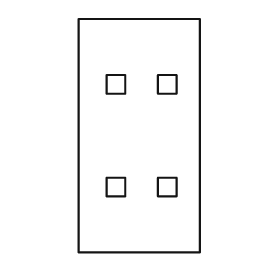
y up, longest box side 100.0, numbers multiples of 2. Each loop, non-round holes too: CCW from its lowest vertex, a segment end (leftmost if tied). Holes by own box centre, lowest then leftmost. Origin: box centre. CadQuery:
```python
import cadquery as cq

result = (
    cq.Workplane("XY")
    .moveTo(-26.0, -50.0)
    .lineTo(26.0, -50.0)
    .lineTo(26.0, 50.0)
    .lineTo(-26.0, 50.0)
    .close()
    .moveTo(-14.0, -26.0)
    .lineTo(-6.0, -26.0)
    .lineTo(-6.0, -18.0)
    .lineTo(-14.0, -18.0)
    .close()
    .moveTo(8.0, -26.0)
    .lineTo(16.0, -26.0)
    .lineTo(16.0, -18.0)
    .lineTo(8.0, -18.0)
    .close()
    .moveTo(-14.0, 18.0)
    .lineTo(-6.0, 18.0)
    .lineTo(-6.0, 26.0)
    .lineTo(-14.0, 26.0)
    .close()
    .moveTo(8.0, 18.0)
    .lineTo(16.0, 18.0)
    .lineTo(16.0, 26.0)
    .lineTo(8.0, 26.0)
    .close()
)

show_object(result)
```